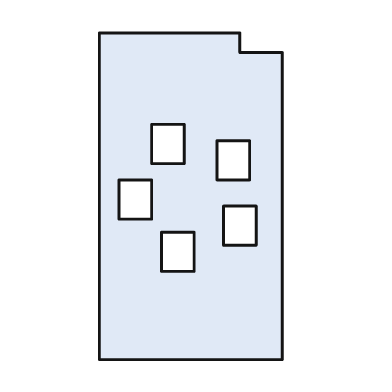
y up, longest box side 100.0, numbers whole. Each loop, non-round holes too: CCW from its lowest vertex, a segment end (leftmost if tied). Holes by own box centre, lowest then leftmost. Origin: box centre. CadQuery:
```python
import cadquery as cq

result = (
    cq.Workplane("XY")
    .moveTo(-28.0, -50.0)
    .lineTo(28.0, -50.0)
    .lineTo(28.0, 44.0)
    .lineTo(15.0, 44.0)
    .lineTo(15.0, 50.0)
    .lineTo(-28.0, 50.0)
    .close()
    .moveTo(-9.0, -23.0)
    .lineTo(1.0, -23.0)
    .lineTo(1.0, -11.0)
    .lineTo(-9.0, -11.0)
    .close()
    .moveTo(10.0, -15.0)
    .lineTo(20.0, -15.0)
    .lineTo(20.0, -3.0)
    .lineTo(10.0, -3.0)
    .close()
    .moveTo(-22.0, -7.0)
    .lineTo(-12.0, -7.0)
    .lineTo(-12.0, 5.0)
    .lineTo(-22.0, 5.0)
    .close()
    .moveTo(8.0, 5.0)
    .lineTo(18.0, 5.0)
    .lineTo(18.0, 17.0)
    .lineTo(8.0, 17.0)
    .close()
    .moveTo(-12.0, 10.0)
    .lineTo(-2.0, 10.0)
    .lineTo(-2.0, 22.0)
    .lineTo(-12.0, 22.0)
    .close()
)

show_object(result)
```